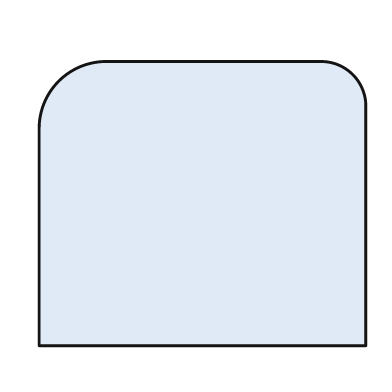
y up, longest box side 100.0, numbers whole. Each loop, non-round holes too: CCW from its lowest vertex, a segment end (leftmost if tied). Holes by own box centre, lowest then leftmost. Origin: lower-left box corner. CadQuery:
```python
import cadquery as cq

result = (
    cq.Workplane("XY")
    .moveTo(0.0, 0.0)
    .lineTo(100.0, 0.0)
    .lineTo(100.0, 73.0)
    .threePointArc((96.0, 83.0), (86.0, 87.0))
    .lineTo(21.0, 87.0)
    .threePointArc((6.0, 81.0), (0.0, 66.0))
    .close()
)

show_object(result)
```